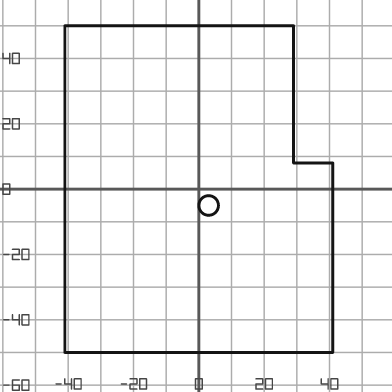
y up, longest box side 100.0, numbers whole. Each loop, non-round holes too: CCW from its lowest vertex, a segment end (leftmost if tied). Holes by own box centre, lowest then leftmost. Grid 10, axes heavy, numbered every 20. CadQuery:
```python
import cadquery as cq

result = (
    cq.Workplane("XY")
    .moveTo(-41.0, -50.0)
    .lineTo(41.0, -50.0)
    .lineTo(41.0, 8.0)
    .lineTo(29.0, 8.0)
    .lineTo(29.0, 50.0)
    .lineTo(-41.0, 50.0)
    .close()
    .moveTo(3.0, -5.0)
    .circle(3.0)
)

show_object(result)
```